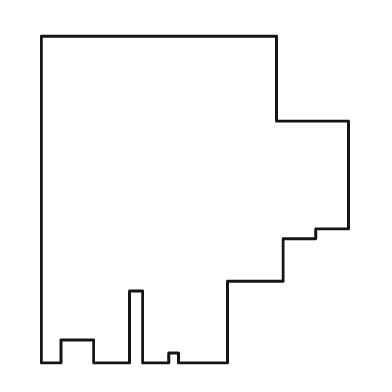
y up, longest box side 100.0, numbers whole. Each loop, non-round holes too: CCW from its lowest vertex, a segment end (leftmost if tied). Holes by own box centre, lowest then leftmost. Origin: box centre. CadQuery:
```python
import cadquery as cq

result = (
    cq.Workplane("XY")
    .moveTo(-47.0, -50.0)
    .lineTo(-41.0, -50.0)
    .lineTo(-41.0, -43.0)
    .lineTo(-31.0, -43.0)
    .lineTo(-31.0, -50.0)
    .lineTo(-20.0, -50.0)
    .lineTo(-20.0, -28.0)
    .lineTo(-16.0, -28.0)
    .lineTo(-16.0, -50.0)
    .lineTo(-8.0, -50.0)
    .lineTo(-8.0, -47.0)
    .lineTo(-5.0, -47.0)
    .lineTo(-5.0, -50.0)
    .lineTo(10.0, -50.0)
    .lineTo(10.0, -25.0)
    .lineTo(27.0, -25.0)
    .lineTo(27.0, -12.0)
    .lineTo(37.0, -12.0)
    .lineTo(37.0, -9.0)
    .lineTo(47.0, -9.0)
    .lineTo(47.0, 24.0)
    .lineTo(25.0, 24.0)
    .lineTo(25.0, 50.0)
    .lineTo(-47.0, 50.0)
    .close()
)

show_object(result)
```